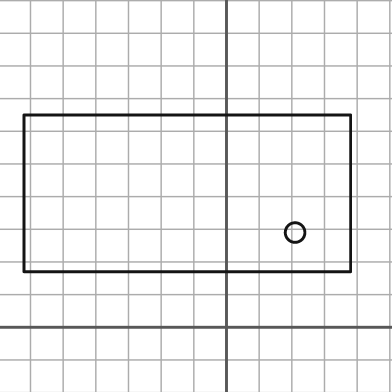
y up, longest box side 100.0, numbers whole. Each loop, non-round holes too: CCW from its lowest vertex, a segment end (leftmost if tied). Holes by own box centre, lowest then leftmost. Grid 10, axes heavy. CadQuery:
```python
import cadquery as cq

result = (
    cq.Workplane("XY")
    .moveTo(-62.0, 17.0)
    .lineTo(38.0, 17.0)
    .lineTo(38.0, 65.0)
    .lineTo(-62.0, 65.0)
    .close()
    .moveTo(21.0, 29.0)
    .circle(3.0)
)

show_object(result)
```